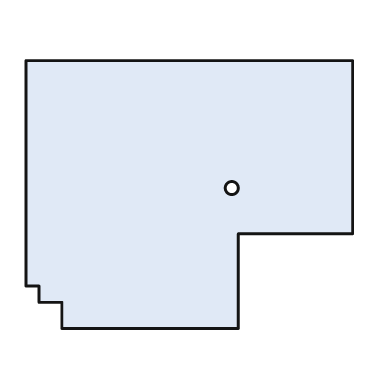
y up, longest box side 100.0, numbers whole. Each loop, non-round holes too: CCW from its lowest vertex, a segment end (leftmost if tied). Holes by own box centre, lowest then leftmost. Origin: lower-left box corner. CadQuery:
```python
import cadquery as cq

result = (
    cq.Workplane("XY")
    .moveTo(11.0, 0.0)
    .lineTo(65.0, 0.0)
    .lineTo(65.0, 29.0)
    .lineTo(100.0, 29.0)
    .lineTo(100.0, 82.0)
    .lineTo(0.0, 82.0)
    .lineTo(0.0, 13.0)
    .lineTo(4.0, 13.0)
    .lineTo(4.0, 8.0)
    .lineTo(11.0, 8.0)
    .close()
    .moveTo(63.0, 43.0)
    .circle(2.0)
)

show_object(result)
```